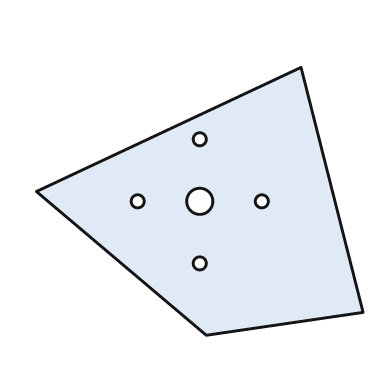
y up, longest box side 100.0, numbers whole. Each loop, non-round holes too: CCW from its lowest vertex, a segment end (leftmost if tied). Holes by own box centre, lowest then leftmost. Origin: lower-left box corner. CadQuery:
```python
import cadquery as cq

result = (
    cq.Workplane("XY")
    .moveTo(52.0, 0.0)
    .lineTo(100.0, 7.0)
    .lineTo(81.0, 82.0)
    .lineTo(0.0, 44.0)
    .close()
    .moveTo(50.0, 22.0)
    .circle(2.0)
    .moveTo(31.0, 41.0)
    .circle(2.0)
    .moveTo(50.0, 41.0)
    .circle(4.0)
    .moveTo(69.0, 41.0)
    .circle(2.0)
    .moveTo(50.0, 60.0)
    .circle(2.0)
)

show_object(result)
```